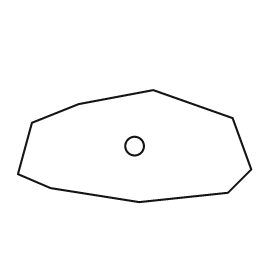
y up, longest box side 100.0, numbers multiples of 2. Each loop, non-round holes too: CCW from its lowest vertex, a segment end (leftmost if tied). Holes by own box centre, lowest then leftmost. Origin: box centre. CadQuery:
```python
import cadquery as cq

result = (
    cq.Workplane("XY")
    .moveTo(2.0, -24.0)
    .lineTo(40.0, -20.0)
    .lineTo(50.0, -10.0)
    .lineTo(42.0, 12.0)
    .lineTo(8.0, 24.0)
    .lineTo(-24.0, 18.0)
    .lineTo(-44.0, 10.0)
    .lineTo(-50.0, -12.0)
    .lineTo(-36.0, -18.0)
    .close()
    .moveTo(0.0, 0.0)
    .circle(4.0)
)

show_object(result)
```